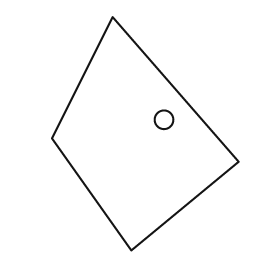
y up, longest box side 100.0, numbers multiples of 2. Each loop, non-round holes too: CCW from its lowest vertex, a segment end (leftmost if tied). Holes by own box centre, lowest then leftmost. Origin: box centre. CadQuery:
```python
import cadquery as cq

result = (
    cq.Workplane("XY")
    .moveTo(-6.0, -50.0)
    .lineTo(40.0, -12.0)
    .lineTo(-14.0, 50.0)
    .lineTo(-40.0, -2.0)
    .close()
    .moveTo(8.0, 6.0)
    .circle(4.0)
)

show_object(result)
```